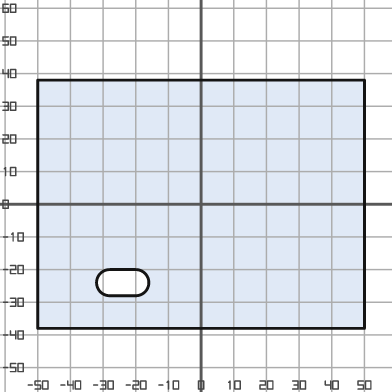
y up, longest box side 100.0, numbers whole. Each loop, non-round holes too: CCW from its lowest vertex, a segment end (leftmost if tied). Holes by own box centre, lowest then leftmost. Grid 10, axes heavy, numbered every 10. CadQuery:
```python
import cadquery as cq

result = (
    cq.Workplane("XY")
    .moveTo(-50.0, -38.0)
    .lineTo(50.0, -38.0)
    .lineTo(50.0, 38.0)
    .lineTo(-50.0, 38.0)
    .close()
    .moveTo(-28.0, -28.0)
    .lineTo(-20.0, -28.0)
    .threePointArc((-16.0, -24.0), (-20.0, -20.0))
    .lineTo(-28.0, -20.0)
    .threePointArc((-32.0, -24.0), (-28.0, -28.0))
    .close()
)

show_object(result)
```